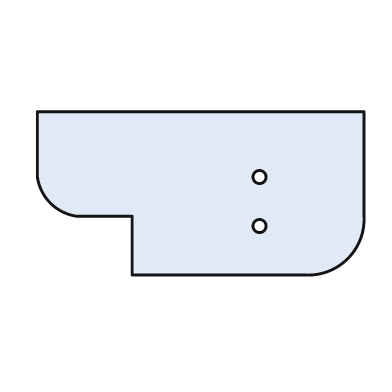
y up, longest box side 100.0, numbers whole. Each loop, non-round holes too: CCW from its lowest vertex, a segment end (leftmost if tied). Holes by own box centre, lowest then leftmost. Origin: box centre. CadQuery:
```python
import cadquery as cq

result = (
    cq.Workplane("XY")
    .moveTo(-21.0, -25.0)
    .lineTo(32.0, -25.0)
    .threePointArc((45.0, -20.0), (50.0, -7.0))
    .lineTo(50.0, 25.0)
    .lineTo(-50.0, 25.0)
    .lineTo(-50.0, 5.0)
    .threePointArc((-46.0, -3.0), (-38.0, -7.0))
    .lineTo(-21.0, -7.0)
    .close()
    .moveTo(18.0, -10.0)
    .circle(2.0)
    .moveTo(18.0, 5.0)
    .circle(2.0)
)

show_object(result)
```